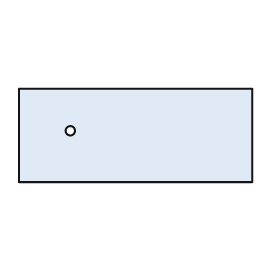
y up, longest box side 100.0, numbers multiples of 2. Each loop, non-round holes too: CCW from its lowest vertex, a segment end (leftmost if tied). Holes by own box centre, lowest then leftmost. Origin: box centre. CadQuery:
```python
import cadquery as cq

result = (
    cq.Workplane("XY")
    .moveTo(-50.0, -20.0)
    .lineTo(50.0, -20.0)
    .lineTo(50.0, 20.0)
    .lineTo(-50.0, 20.0)
    .close()
    .moveTo(-28.0, 2.0)
    .circle(2.0)
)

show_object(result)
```